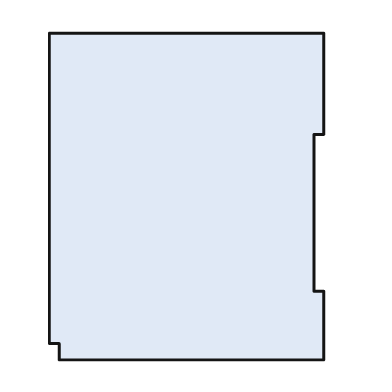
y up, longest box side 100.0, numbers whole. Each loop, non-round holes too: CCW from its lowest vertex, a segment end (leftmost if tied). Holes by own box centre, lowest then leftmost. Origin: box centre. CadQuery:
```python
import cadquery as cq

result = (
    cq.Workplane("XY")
    .moveTo(-39.0, -50.0)
    .lineTo(42.0, -50.0)
    .lineTo(42.0, -29.0)
    .lineTo(39.0, -29.0)
    .lineTo(39.0, 19.0)
    .lineTo(42.0, 19.0)
    .lineTo(42.0, 50.0)
    .lineTo(-42.0, 50.0)
    .lineTo(-42.0, -45.0)
    .lineTo(-39.0, -45.0)
    .close()
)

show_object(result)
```